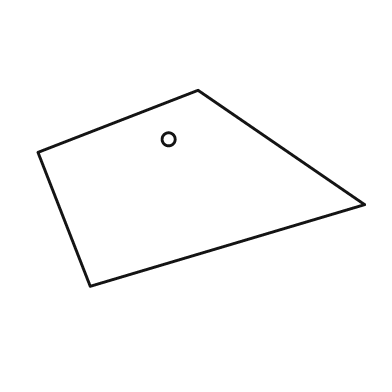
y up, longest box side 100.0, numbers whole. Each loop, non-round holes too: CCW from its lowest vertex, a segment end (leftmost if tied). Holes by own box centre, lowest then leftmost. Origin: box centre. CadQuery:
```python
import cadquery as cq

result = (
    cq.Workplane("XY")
    .moveTo(-34.0, -30.0)
    .lineTo(50.0, -5.0)
    .lineTo(-1.0, 30.0)
    .lineTo(-50.0, 11.0)
    .close()
    .moveTo(-10.0, 15.0)
    .circle(2.0)
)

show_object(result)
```